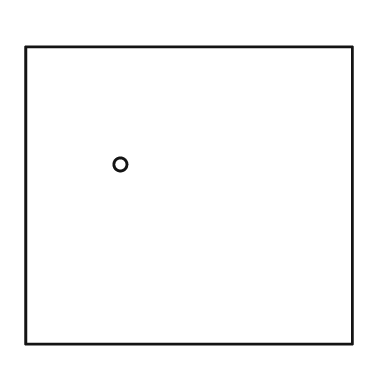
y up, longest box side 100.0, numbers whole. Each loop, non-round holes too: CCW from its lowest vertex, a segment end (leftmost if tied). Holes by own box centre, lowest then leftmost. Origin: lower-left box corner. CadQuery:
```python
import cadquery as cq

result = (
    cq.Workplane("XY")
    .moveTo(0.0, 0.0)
    .lineTo(100.0, 0.0)
    .lineTo(100.0, 91.0)
    .lineTo(0.0, 91.0)
    .close()
    .moveTo(29.0, 55.0)
    .circle(2.0)
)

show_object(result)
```